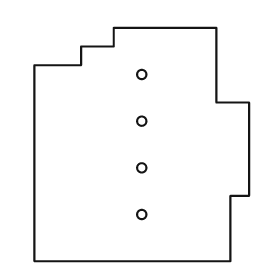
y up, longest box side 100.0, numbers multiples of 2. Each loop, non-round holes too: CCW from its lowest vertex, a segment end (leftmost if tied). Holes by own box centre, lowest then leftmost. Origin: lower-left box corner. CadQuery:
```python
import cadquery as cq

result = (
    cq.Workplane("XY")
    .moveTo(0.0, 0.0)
    .lineTo(84.0, 0.0)
    .lineTo(84.0, 28.0)
    .lineTo(92.0, 28.0)
    .lineTo(92.0, 68.0)
    .lineTo(78.0, 68.0)
    .lineTo(78.0, 100.0)
    .lineTo(34.0, 100.0)
    .lineTo(34.0, 92.0)
    .lineTo(20.0, 92.0)
    .lineTo(20.0, 84.0)
    .lineTo(0.0, 84.0)
    .close()
    .moveTo(46.0, 20.0)
    .circle(2.0)
    .moveTo(46.0, 40.0)
    .circle(2.0)
    .moveTo(46.0, 60.0)
    .circle(2.0)
    .moveTo(46.0, 80.0)
    .circle(2.0)
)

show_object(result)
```